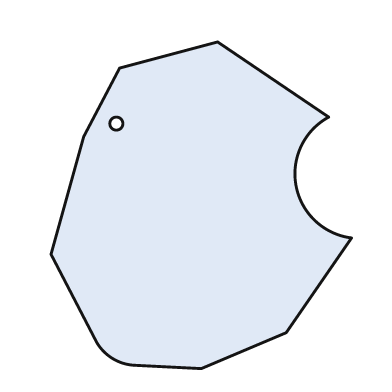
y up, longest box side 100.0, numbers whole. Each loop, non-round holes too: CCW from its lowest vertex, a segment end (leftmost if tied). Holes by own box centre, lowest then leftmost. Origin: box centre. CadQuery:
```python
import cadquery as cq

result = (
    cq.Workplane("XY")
    .moveTo(0.0, -50.0)
    .lineTo(26.0, -39.0)
    .lineTo(46.0, -10.0)
    .threePointArc((29.0, 6.0), (39.0, 27.0))
    .lineTo(5.0, 50.0)
    .lineTo(-25.0, 42.0)
    .lineTo(-36.0, 21.0)
    .lineTo(-46.0, -15.0)
    .lineTo(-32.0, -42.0)
    .threePointArc((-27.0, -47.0), (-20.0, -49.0))
    .close()
    .moveTo(-26.0, 25.0)
    .circle(2.0)
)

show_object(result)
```